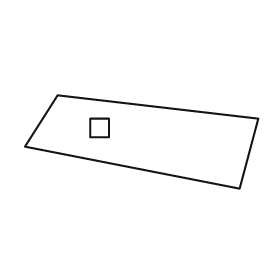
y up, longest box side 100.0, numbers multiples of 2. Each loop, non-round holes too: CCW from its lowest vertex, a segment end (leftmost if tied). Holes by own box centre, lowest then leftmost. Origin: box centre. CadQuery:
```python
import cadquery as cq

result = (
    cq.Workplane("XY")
    .moveTo(42.0, -20.0)
    .lineTo(50.0, 10.0)
    .lineTo(-36.0, 20.0)
    .lineTo(-50.0, -2.0)
    .close()
    .moveTo(-22.0, 2.0)
    .lineTo(-14.0, 2.0)
    .lineTo(-14.0, 10.0)
    .lineTo(-22.0, 10.0)
    .close()
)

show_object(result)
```